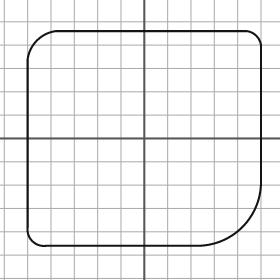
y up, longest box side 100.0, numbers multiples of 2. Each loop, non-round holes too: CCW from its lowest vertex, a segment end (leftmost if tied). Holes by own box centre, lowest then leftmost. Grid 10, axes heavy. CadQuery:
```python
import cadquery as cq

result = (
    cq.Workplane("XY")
    .moveTo(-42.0, -46.0)
    .lineTo(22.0, -46.0)
    .threePointArc((42.0, -38.0), (50.0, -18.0))
    .lineTo(50.0, 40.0)
    .threePointArc((48.0, 44.0), (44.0, 46.0))
    .lineTo(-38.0, 46.0)
    .threePointArc((-46.0, 42.0), (-50.0, 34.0))
    .lineTo(-50.0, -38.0)
    .threePointArc((-48.0, -44.0), (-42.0, -46.0))
    .close()
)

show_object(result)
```